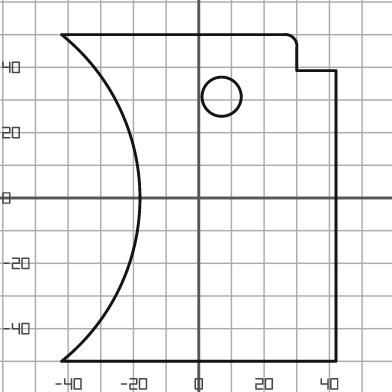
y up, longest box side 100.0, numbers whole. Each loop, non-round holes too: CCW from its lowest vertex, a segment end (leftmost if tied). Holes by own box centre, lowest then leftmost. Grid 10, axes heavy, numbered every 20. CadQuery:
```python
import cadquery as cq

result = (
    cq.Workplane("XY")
    .moveTo(-42.0, -50.0)
    .lineTo(42.0, -50.0)
    .lineTo(42.0, 39.0)
    .lineTo(30.0, 39.0)
    .lineTo(30.0, 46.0)
    .threePointArc((29.0, 49.0), (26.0, 50.0))
    .lineTo(-42.0, 50.0)
    .threePointArc((-18.0, 0.0), (-42.0, -50.0))
    .close()
    .moveTo(7.0, 31.0)
    .circle(6.0)
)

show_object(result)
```